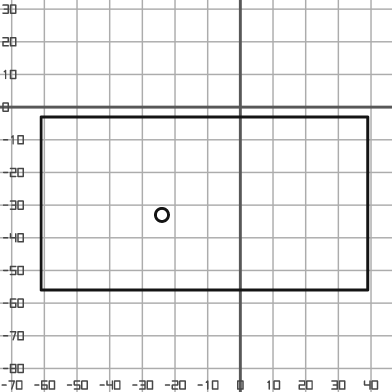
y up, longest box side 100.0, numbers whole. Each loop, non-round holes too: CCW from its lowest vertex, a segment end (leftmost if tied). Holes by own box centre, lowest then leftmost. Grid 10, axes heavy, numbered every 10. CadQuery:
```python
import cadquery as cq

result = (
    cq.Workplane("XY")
    .moveTo(-61.0, -56.0)
    .lineTo(39.0, -56.0)
    .lineTo(39.0, -3.0)
    .lineTo(-61.0, -3.0)
    .close()
    .moveTo(-24.0, -33.0)
    .circle(2.0)
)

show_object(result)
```